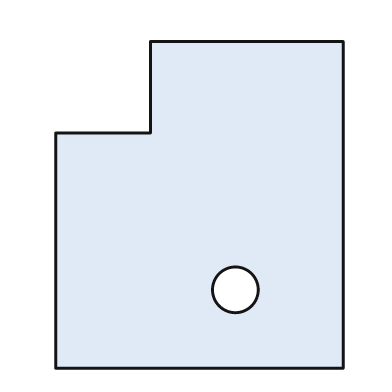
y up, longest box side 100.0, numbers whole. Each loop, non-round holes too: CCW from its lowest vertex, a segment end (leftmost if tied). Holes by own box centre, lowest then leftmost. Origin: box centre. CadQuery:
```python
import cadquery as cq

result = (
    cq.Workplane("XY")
    .moveTo(-44.0, -50.0)
    .lineTo(44.0, -50.0)
    .lineTo(44.0, 50.0)
    .lineTo(-15.0, 50.0)
    .lineTo(-15.0, 22.0)
    .lineTo(-44.0, 22.0)
    .close()
    .moveTo(11.0, -26.0)
    .circle(7.0)
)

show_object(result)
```